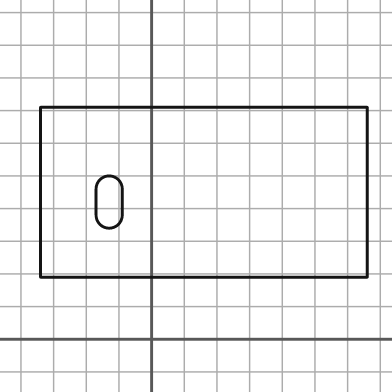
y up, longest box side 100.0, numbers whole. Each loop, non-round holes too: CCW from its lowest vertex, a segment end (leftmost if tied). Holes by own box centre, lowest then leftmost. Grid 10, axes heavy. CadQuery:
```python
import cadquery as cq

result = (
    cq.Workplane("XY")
    .moveTo(-34.0, 19.0)
    .lineTo(66.0, 19.0)
    .lineTo(66.0, 71.0)
    .lineTo(-34.0, 71.0)
    .close()
    .moveTo(-17.0, 38.0)
    .threePointArc((-13.0, 34.0), (-9.0, 38.0))
    .lineTo(-9.0, 46.0)
    .threePointArc((-13.0, 50.0), (-17.0, 46.0))
    .close()
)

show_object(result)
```